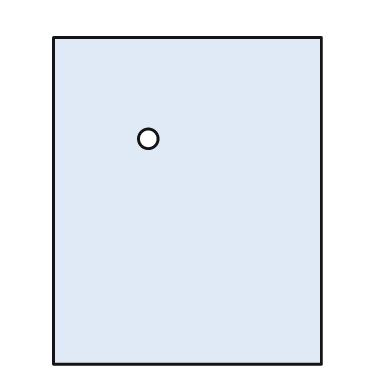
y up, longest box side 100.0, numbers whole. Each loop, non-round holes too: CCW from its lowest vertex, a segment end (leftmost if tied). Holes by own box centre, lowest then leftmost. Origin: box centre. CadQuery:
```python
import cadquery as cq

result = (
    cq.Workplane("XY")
    .moveTo(-41.0, -50.0)
    .lineTo(41.0, -50.0)
    .lineTo(41.0, 50.0)
    .lineTo(-41.0, 50.0)
    .close()
    .moveTo(-12.0, 19.0)
    .circle(3.0)
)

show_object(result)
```